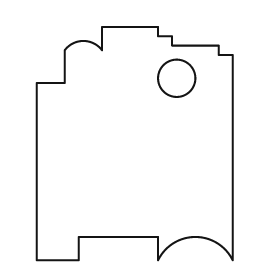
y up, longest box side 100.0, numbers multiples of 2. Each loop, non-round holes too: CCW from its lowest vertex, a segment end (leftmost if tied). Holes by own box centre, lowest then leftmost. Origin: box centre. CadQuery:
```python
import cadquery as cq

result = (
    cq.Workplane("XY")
    .moveTo(-42.0, -50.0)
    .lineTo(-24.0, -50.0)
    .lineTo(-24.0, -40.0)
    .lineTo(10.0, -40.0)
    .lineTo(10.0, -50.0)
    .threePointArc((26.0, -40.0), (42.0, -50.0))
    .lineTo(42.0, 38.0)
    .lineTo(36.0, 38.0)
    .lineTo(36.0, 42.0)
    .lineTo(16.0, 42.0)
    .lineTo(16.0, 46.0)
    .lineTo(10.0, 46.0)
    .lineTo(10.0, 50.0)
    .lineTo(-14.0, 50.0)
    .lineTo(-14.0, 40.0)
    .threePointArc((-22.0, 44.0), (-30.0, 40.0))
    .lineTo(-30.0, 26.0)
    .lineTo(-42.0, 26.0)
    .close()
    .moveTo(18.0, 28.0)
    .circle(8.0)
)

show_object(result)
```